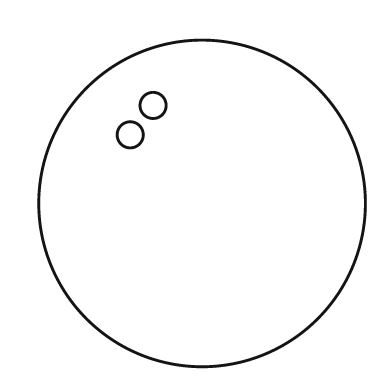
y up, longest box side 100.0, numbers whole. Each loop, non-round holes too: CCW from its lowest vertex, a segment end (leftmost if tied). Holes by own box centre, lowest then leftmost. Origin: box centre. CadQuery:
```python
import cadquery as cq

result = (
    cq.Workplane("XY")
    .moveTo(0.0, 0.0)
    .circle(50.0)
    .moveTo(-22.0, 21.0)
    .circle(4.0)
    .moveTo(-15.0, 30.0)
    .circle(4.0)
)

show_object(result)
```